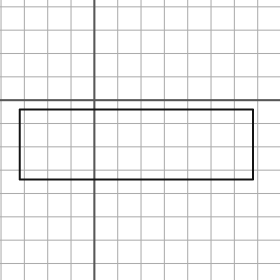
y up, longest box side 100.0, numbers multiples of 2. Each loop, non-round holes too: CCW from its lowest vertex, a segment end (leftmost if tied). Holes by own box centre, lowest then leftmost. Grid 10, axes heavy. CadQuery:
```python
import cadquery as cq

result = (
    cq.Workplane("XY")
    .moveTo(-32.0, -34.0)
    .lineTo(68.0, -34.0)
    .lineTo(68.0, -4.0)
    .lineTo(-32.0, -4.0)
    .close()
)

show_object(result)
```